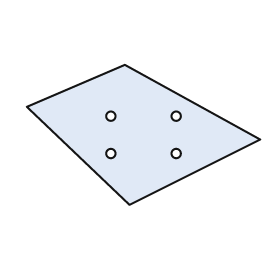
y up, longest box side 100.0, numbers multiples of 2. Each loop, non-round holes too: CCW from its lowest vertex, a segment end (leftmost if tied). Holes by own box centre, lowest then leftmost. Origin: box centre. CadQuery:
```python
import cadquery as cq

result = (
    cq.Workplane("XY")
    .moveTo(-6.0, -30.0)
    .lineTo(50.0, -2.0)
    .lineTo(-8.0, 30.0)
    .lineTo(-50.0, 12.0)
    .close()
    .moveTo(-14.0, -8.0)
    .circle(2.0)
    .moveTo(14.0, -8.0)
    .circle(2.0)
    .moveTo(-14.0, 8.0)
    .circle(2.0)
    .moveTo(14.0, 8.0)
    .circle(2.0)
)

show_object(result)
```